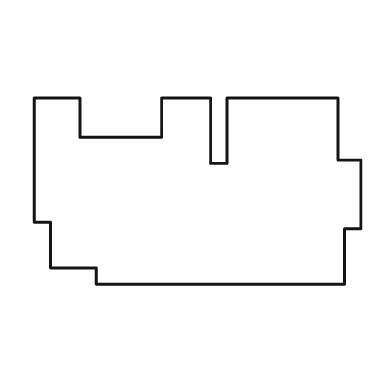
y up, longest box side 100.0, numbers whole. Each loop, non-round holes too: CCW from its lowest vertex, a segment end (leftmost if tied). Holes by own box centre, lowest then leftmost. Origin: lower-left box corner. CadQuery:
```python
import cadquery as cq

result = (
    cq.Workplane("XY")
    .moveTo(19.0, 0.0)
    .lineTo(95.0, 0.0)
    .lineTo(95.0, 17.0)
    .lineTo(100.0, 17.0)
    .lineTo(100.0, 38.0)
    .lineTo(93.0, 38.0)
    .lineTo(93.0, 57.0)
    .lineTo(59.0, 57.0)
    .lineTo(59.0, 37.0)
    .lineTo(54.0, 37.0)
    .lineTo(54.0, 57.0)
    .lineTo(39.0, 57.0)
    .lineTo(39.0, 45.0)
    .lineTo(14.0, 45.0)
    .lineTo(14.0, 57.0)
    .lineTo(0.0, 57.0)
    .lineTo(0.0, 19.0)
    .lineTo(5.0, 19.0)
    .lineTo(5.0, 5.0)
    .lineTo(19.0, 5.0)
    .close()
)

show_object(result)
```